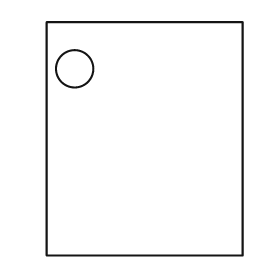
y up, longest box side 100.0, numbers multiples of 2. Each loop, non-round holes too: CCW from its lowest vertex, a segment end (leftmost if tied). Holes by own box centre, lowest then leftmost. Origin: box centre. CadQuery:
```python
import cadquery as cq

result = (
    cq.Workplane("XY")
    .moveTo(-42.0, -50.0)
    .lineTo(42.0, -50.0)
    .lineTo(42.0, 50.0)
    .lineTo(-42.0, 50.0)
    .close()
    .moveTo(-30.0, 30.0)
    .circle(8.0)
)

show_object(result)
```